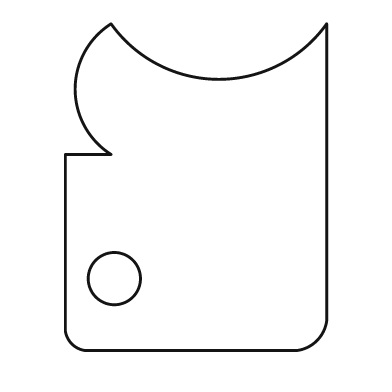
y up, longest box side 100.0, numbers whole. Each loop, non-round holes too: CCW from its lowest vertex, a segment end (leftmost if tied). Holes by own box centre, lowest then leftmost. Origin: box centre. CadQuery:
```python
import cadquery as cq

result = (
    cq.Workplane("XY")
    .moveTo(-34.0, -50.0)
    .lineTo(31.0, -50.0)
    .threePointArc((37.0, -47.0), (40.0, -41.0))
    .lineTo(40.0, 50.0)
    .threePointArc((7.0, 33.0), (-26.0, 50.0))
    .threePointArc((-37.0, 30.0), (-26.0, 10.0))
    .lineTo(-40.0, 10.0)
    .lineTo(-40.0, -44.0)
    .threePointArc((-38.0, -48.0), (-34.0, -50.0))
    .close()
    .moveTo(-25.0, -28.0)
    .circle(8.0)
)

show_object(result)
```